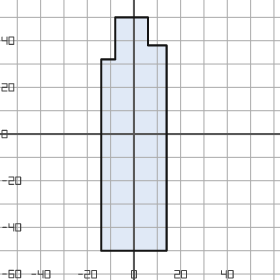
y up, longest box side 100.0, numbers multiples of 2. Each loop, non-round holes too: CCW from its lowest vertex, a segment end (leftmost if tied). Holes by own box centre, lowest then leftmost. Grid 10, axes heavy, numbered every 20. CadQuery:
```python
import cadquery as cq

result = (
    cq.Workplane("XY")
    .moveTo(-14.0, -50.0)
    .lineTo(14.0, -50.0)
    .lineTo(14.0, 38.0)
    .lineTo(6.0, 38.0)
    .lineTo(6.0, 50.0)
    .lineTo(-8.0, 50.0)
    .lineTo(-8.0, 32.0)
    .lineTo(-14.0, 32.0)
    .close()
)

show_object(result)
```